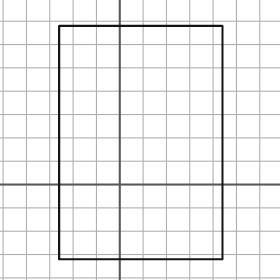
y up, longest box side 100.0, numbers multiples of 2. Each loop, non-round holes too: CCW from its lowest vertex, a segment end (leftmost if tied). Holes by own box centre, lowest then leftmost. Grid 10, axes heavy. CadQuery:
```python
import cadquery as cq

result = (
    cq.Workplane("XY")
    .moveTo(-26.0, -32.0)
    .lineTo(44.0, -32.0)
    .lineTo(44.0, 68.0)
    .lineTo(-26.0, 68.0)
    .close()
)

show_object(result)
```